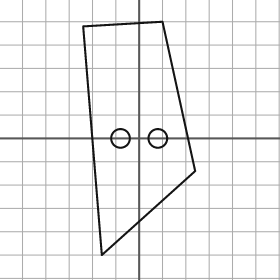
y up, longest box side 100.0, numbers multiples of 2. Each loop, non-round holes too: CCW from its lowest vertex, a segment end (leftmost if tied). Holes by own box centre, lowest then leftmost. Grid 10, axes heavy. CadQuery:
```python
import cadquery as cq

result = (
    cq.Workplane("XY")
    .moveTo(-16.0, -50.0)
    .lineTo(24.0, -14.0)
    .lineTo(10.0, 50.0)
    .lineTo(-24.0, 48.0)
    .close()
    .moveTo(-8.0, 0.0)
    .circle(4.0)
    .moveTo(8.0, 0.0)
    .circle(4.0)
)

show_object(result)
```